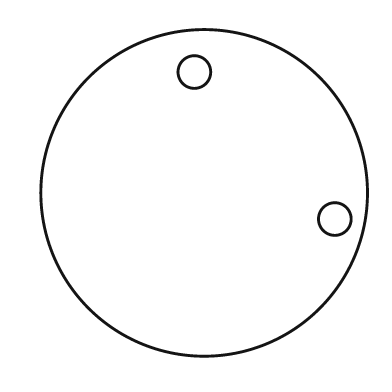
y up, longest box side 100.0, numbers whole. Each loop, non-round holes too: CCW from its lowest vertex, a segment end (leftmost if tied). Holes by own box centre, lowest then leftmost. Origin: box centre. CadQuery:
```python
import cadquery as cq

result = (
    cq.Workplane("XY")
    .moveTo(0.0, 0.0)
    .circle(50.0)
    .moveTo(40.0, -8.0)
    .circle(5.0)
    .moveTo(-3.0, 37.0)
    .circle(5.0)
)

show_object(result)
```